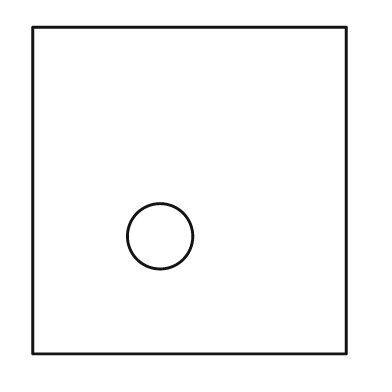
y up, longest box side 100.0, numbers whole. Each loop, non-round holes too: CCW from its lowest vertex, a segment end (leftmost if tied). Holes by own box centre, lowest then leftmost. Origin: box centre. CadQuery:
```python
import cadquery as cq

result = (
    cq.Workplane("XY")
    .moveTo(-48.0, -50.0)
    .lineTo(48.0, -50.0)
    .lineTo(48.0, 50.0)
    .lineTo(-48.0, 50.0)
    .close()
    .moveTo(-9.0, -14.0)
    .circle(10.0)
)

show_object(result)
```